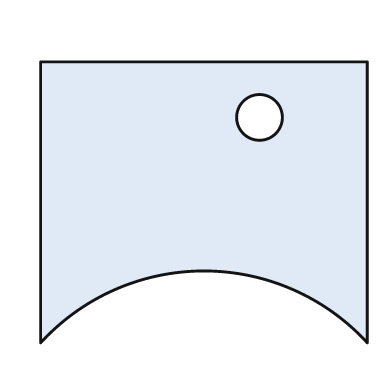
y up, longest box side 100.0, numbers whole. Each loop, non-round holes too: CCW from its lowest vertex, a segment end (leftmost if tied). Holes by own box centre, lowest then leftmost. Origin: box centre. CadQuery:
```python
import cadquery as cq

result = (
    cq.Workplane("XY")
    .moveTo(-50.0, -43.0)
    .threePointArc((0.0, -21.0), (50.0, -43.0))
    .lineTo(50.0, 43.0)
    .lineTo(-50.0, 43.0)
    .close()
    .moveTo(17.0, 26.0)
    .circle(7.0)
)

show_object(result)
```